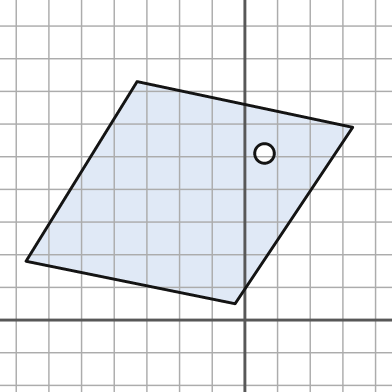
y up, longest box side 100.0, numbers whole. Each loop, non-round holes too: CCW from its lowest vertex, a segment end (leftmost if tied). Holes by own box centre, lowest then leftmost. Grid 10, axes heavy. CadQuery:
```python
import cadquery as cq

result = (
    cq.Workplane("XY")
    .moveTo(-3.0, 5.0)
    .lineTo(33.0, 59.0)
    .lineTo(-33.0, 73.0)
    .lineTo(-67.0, 18.0)
    .close()
    .moveTo(6.0, 51.0)
    .circle(3.0)
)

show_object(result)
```